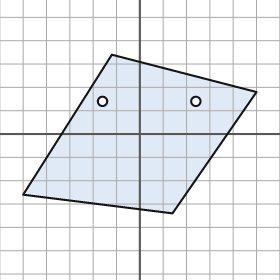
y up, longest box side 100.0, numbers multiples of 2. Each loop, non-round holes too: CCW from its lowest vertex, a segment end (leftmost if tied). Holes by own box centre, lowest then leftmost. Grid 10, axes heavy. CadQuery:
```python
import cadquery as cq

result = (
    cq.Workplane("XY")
    .moveTo(14.0, -34.0)
    .lineTo(50.0, 18.0)
    .lineTo(-12.0, 34.0)
    .lineTo(-50.0, -26.0)
    .close()
    .moveTo(-16.0, 14.0)
    .circle(2.0)
    .moveTo(24.0, 14.0)
    .circle(2.0)
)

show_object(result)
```